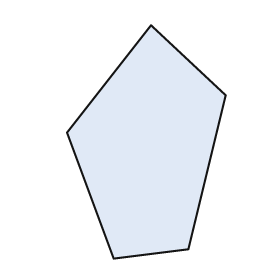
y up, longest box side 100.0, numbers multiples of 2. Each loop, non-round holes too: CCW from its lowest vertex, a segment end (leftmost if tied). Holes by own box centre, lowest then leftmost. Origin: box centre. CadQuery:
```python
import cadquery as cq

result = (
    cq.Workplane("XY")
    .moveTo(-14.0, -50.0)
    .lineTo(18.0, -46.0)
    .lineTo(34.0, 20.0)
    .lineTo(2.0, 50.0)
    .lineTo(-34.0, 4.0)
    .close()
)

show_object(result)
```